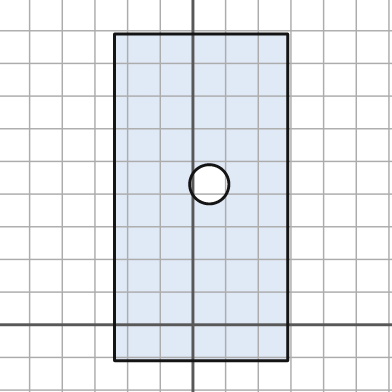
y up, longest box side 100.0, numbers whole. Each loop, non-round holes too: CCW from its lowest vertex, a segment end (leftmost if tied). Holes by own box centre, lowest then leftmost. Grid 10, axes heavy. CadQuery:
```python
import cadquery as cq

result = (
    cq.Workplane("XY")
    .moveTo(-24.0, -11.0)
    .lineTo(29.0, -11.0)
    .lineTo(29.0, 89.0)
    .lineTo(-24.0, 89.0)
    .close()
    .moveTo(5.0, 43.0)
    .circle(6.0)
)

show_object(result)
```